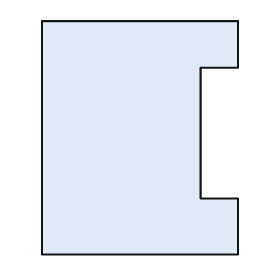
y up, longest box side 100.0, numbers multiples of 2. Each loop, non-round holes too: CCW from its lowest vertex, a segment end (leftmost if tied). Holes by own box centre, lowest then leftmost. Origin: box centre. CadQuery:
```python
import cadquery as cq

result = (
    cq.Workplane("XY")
    .moveTo(-42.0, -50.0)
    .lineTo(42.0, -50.0)
    .lineTo(42.0, -26.0)
    .lineTo(26.0, -26.0)
    .lineTo(26.0, 30.0)
    .lineTo(42.0, 30.0)
    .lineTo(42.0, 50.0)
    .lineTo(-42.0, 50.0)
    .close()
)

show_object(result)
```